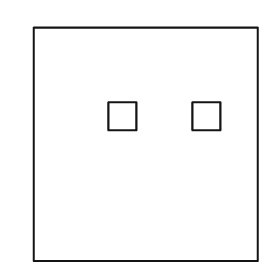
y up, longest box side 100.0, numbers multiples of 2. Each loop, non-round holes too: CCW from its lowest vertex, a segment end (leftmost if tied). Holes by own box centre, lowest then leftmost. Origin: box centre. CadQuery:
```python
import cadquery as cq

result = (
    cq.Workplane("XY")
    .moveTo(-48.0, -50.0)
    .lineTo(48.0, -50.0)
    .lineTo(48.0, 50.0)
    .lineTo(-48.0, 50.0)
    .close()
    .moveTo(-16.0, 6.0)
    .lineTo(-4.0, 6.0)
    .lineTo(-4.0, 18.0)
    .lineTo(-16.0, 18.0)
    .close()
    .moveTo(20.0, 6.0)
    .lineTo(32.0, 6.0)
    .lineTo(32.0, 18.0)
    .lineTo(20.0, 18.0)
    .close()
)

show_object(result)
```